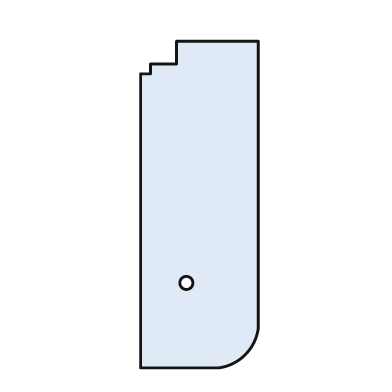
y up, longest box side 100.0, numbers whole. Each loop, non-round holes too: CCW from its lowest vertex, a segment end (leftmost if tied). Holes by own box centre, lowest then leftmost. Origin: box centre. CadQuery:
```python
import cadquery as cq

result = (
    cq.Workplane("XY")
    .moveTo(-18.0, -50.0)
    .lineTo(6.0, -50.0)
    .threePointArc((14.0, -46.0), (18.0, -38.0))
    .lineTo(18.0, 50.0)
    .lineTo(-7.0, 50.0)
    .lineTo(-7.0, 43.0)
    .lineTo(-15.0, 43.0)
    .lineTo(-15.0, 40.0)
    .lineTo(-18.0, 40.0)
    .close()
    .moveTo(-4.0, -24.0)
    .circle(2.0)
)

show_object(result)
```